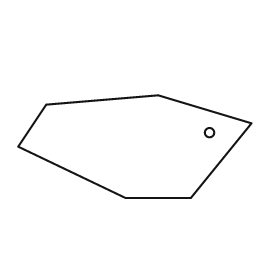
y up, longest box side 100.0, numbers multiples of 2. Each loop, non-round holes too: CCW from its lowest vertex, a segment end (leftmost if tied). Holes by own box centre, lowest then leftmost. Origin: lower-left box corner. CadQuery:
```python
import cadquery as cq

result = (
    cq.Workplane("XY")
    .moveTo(46.0, 0.0)
    .lineTo(74.0, 0.0)
    .lineTo(100.0, 32.0)
    .lineTo(60.0, 44.0)
    .lineTo(12.0, 40.0)
    .lineTo(0.0, 22.0)
    .close()
    .moveTo(82.0, 28.0)
    .circle(2.0)
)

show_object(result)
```